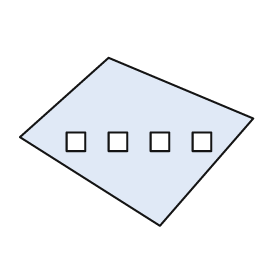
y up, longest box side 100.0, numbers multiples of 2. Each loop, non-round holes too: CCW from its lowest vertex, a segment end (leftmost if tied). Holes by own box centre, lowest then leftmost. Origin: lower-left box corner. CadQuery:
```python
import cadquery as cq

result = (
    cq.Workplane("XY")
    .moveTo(60.0, 0.0)
    .lineTo(100.0, 46.0)
    .lineTo(38.0, 72.0)
    .lineTo(0.0, 38.0)
    .close()
    .moveTo(20.0, 32.0)
    .lineTo(28.0, 32.0)
    .lineTo(28.0, 40.0)
    .lineTo(20.0, 40.0)
    .close()
    .moveTo(38.0, 32.0)
    .lineTo(46.0, 32.0)
    .lineTo(46.0, 40.0)
    .lineTo(38.0, 40.0)
    .close()
    .moveTo(56.0, 32.0)
    .lineTo(64.0, 32.0)
    .lineTo(64.0, 40.0)
    .lineTo(56.0, 40.0)
    .close()
    .moveTo(74.0, 32.0)
    .lineTo(82.0, 32.0)
    .lineTo(82.0, 40.0)
    .lineTo(74.0, 40.0)
    .close()
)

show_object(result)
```